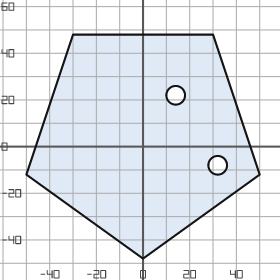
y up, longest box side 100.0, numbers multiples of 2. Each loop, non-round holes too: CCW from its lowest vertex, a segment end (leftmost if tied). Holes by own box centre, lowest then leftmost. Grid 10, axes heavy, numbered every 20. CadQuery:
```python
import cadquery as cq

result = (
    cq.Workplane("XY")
    .moveTo(0.0, -48.0)
    .lineTo(50.0, -12.0)
    .lineTo(30.0, 48.0)
    .lineTo(-30.0, 48.0)
    .lineTo(-50.0, -12.0)
    .close()
    .moveTo(32.0, -8.0)
    .circle(4.0)
    .moveTo(14.0, 22.0)
    .circle(4.0)
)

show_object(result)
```